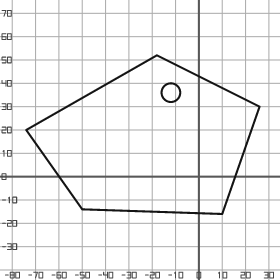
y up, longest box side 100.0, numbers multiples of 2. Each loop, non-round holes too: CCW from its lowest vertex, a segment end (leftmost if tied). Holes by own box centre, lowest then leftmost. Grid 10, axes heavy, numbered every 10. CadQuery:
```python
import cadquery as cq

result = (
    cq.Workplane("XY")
    .moveTo(10.0, -16.0)
    .lineTo(26.0, 30.0)
    .lineTo(-18.0, 52.0)
    .lineTo(-74.0, 20.0)
    .lineTo(-50.0, -14.0)
    .close()
    .moveTo(-12.0, 36.0)
    .circle(4.0)
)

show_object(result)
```